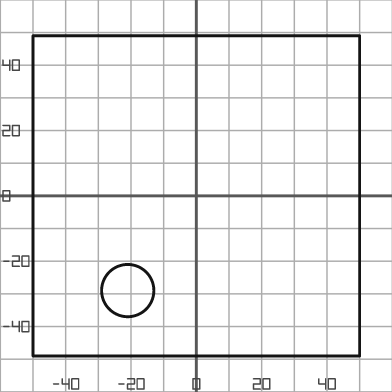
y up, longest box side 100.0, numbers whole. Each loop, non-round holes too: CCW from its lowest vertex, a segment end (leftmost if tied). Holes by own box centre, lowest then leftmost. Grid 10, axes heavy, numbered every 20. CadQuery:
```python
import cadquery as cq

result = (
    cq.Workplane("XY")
    .moveTo(-50.0, -49.0)
    .lineTo(50.0, -49.0)
    .lineTo(50.0, 49.0)
    .lineTo(-50.0, 49.0)
    .close()
    .moveTo(-21.0, -29.0)
    .circle(8.0)
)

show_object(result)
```